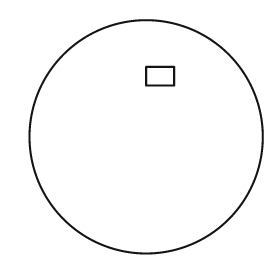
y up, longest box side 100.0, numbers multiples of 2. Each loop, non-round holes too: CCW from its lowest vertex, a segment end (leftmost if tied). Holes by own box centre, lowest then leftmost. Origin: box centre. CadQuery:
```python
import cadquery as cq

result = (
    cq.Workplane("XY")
    .moveTo(0.0, 0.0)
    .circle(50.0)
    .moveTo(0.0, 22.0)
    .lineTo(12.0, 22.0)
    .lineTo(12.0, 30.0)
    .lineTo(0.0, 30.0)
    .close()
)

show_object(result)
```